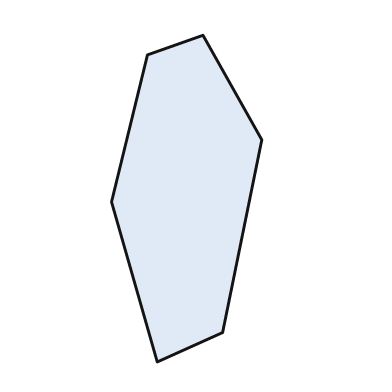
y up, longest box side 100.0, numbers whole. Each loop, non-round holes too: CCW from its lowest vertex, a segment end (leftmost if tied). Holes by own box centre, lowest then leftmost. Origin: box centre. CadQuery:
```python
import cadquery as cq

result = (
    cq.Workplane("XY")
    .moveTo(-9.0, -50.0)
    .lineTo(11.0, -41.0)
    .lineTo(23.0, 18.0)
    .lineTo(5.0, 50.0)
    .lineTo(-12.0, 44.0)
    .lineTo(-23.0, -1.0)
    .close()
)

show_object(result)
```